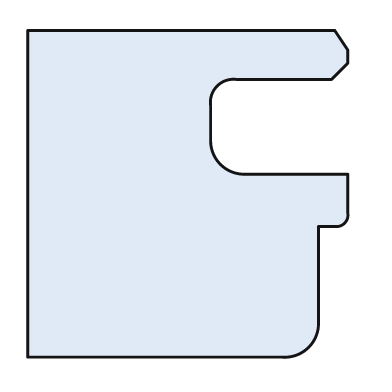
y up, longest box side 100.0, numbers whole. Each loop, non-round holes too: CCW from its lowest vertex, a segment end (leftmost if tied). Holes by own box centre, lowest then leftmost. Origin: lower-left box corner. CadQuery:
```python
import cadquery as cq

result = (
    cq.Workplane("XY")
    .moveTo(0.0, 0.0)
    .lineTo(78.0, 0.0)
    .threePointArc((86.0, 3.0), (89.0, 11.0))
    .lineTo(89.0, 40.0)
    .lineTo(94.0, 40.0)
    .threePointArc((97.0, 41.0), (98.0, 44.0))
    .lineTo(98.0, 56.0)
    .lineTo(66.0, 56.0)
    .threePointArc((59.0, 59.0), (56.0, 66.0))
    .lineTo(56.0, 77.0)
    .threePointArc((58.0, 83.0), (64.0, 85.0))
    .lineTo(93.0, 85.0)
    .lineTo(98.0, 90.0)
    .lineTo(98.0, 94.0)
    .lineTo(94.0, 100.0)
    .lineTo(0.0, 100.0)
    .close()
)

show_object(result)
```